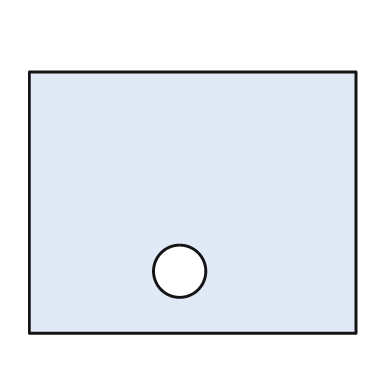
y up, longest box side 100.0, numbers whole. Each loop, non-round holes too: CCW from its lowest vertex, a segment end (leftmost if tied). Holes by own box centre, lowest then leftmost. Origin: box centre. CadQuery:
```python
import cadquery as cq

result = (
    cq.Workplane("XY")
    .moveTo(-50.0, -40.0)
    .lineTo(50.0, -40.0)
    .lineTo(50.0, 40.0)
    .lineTo(-50.0, 40.0)
    .close()
    .moveTo(-4.0, -21.0)
    .circle(8.0)
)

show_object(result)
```